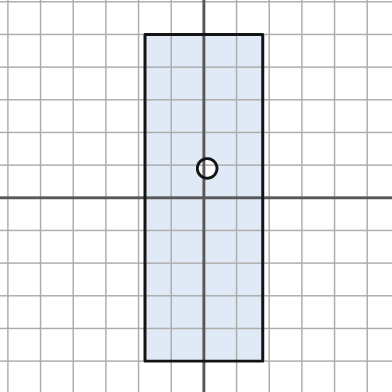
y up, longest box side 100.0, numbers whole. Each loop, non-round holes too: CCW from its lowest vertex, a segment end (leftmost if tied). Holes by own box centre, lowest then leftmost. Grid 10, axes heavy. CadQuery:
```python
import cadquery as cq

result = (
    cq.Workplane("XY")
    .moveTo(-18.0, -50.0)
    .lineTo(18.0, -50.0)
    .lineTo(18.0, 50.0)
    .lineTo(-18.0, 50.0)
    .close()
    .moveTo(1.0, 9.0)
    .circle(3.0)
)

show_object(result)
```